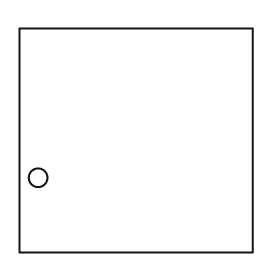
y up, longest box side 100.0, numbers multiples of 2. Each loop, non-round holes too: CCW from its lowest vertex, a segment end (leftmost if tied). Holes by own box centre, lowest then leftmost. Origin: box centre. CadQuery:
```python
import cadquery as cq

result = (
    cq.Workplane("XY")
    .moveTo(-50.0, -48.0)
    .lineTo(50.0, -48.0)
    .lineTo(50.0, 48.0)
    .lineTo(-50.0, 48.0)
    .close()
    .moveTo(-42.0, -16.0)
    .circle(4.0)
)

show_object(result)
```